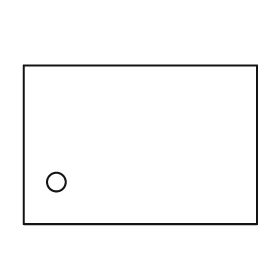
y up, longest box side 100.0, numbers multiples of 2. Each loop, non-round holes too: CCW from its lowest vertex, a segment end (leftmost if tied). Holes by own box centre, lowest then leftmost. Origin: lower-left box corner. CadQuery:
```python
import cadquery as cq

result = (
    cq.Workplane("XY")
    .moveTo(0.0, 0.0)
    .lineTo(100.0, 0.0)
    .lineTo(100.0, 68.0)
    .lineTo(0.0, 68.0)
    .close()
    .moveTo(14.0, 18.0)
    .circle(4.0)
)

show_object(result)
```